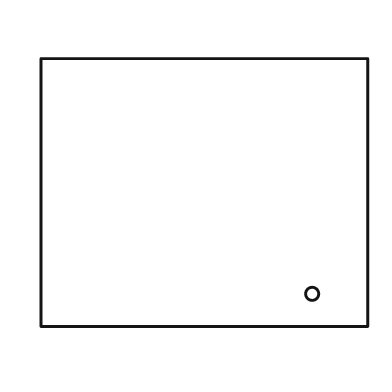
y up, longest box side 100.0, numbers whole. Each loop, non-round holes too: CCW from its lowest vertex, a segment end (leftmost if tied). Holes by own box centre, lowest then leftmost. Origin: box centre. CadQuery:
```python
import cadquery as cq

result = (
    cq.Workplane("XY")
    .moveTo(-50.0, -41.0)
    .lineTo(50.0, -41.0)
    .lineTo(50.0, 41.0)
    .lineTo(-50.0, 41.0)
    .close()
    .moveTo(33.0, -31.0)
    .circle(2.0)
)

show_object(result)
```